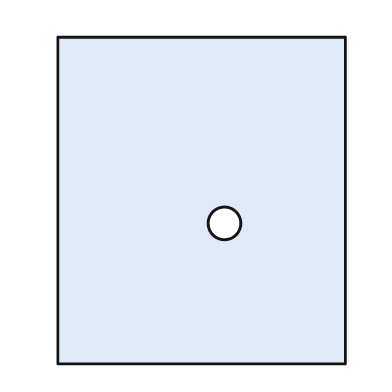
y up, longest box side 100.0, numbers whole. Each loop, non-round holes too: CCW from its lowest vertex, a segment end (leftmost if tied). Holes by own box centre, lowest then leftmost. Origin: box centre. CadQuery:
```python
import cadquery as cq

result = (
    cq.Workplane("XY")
    .moveTo(-44.0, -50.0)
    .lineTo(44.0, -50.0)
    .lineTo(44.0, 50.0)
    .lineTo(-44.0, 50.0)
    .close()
    .moveTo(7.0, -7.0)
    .circle(5.0)
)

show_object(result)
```